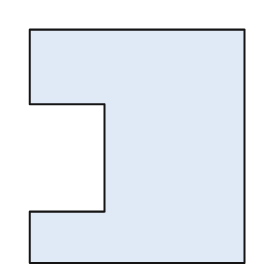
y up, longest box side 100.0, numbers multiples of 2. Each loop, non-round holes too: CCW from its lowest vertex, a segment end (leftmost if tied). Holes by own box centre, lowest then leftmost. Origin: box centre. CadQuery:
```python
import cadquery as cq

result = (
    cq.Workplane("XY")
    .moveTo(-46.0, -50.0)
    .lineTo(46.0, -50.0)
    .lineTo(46.0, 50.0)
    .lineTo(-46.0, 50.0)
    .lineTo(-46.0, 18.0)
    .lineTo(-14.0, 18.0)
    .lineTo(-14.0, -28.0)
    .lineTo(-46.0, -28.0)
    .close()
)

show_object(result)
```